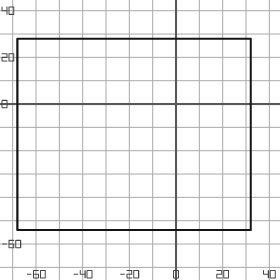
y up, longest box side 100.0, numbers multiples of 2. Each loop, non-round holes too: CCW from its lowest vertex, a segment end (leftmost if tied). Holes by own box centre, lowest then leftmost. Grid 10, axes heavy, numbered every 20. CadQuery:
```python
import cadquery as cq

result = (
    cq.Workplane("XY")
    .moveTo(-68.0, -54.0)
    .lineTo(32.0, -54.0)
    .lineTo(32.0, 28.0)
    .lineTo(-68.0, 28.0)
    .close()
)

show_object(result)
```